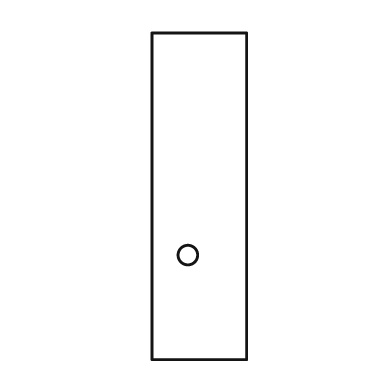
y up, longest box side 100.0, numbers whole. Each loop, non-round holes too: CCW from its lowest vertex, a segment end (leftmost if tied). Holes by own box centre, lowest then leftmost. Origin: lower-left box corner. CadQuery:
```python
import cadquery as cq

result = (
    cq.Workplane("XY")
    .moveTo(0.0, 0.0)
    .lineTo(29.0, 0.0)
    .lineTo(29.0, 100.0)
    .lineTo(0.0, 100.0)
    .close()
    .moveTo(11.0, 32.0)
    .circle(3.0)
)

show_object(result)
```